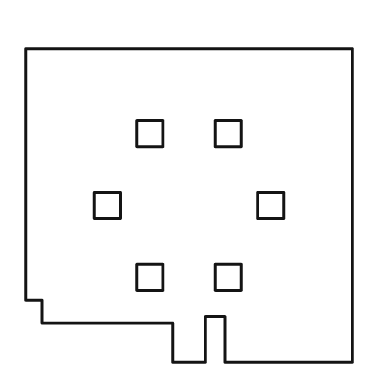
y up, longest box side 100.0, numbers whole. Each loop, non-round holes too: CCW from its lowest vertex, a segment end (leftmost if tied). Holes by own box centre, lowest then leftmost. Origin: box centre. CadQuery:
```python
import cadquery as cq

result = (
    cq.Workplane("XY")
    .moveTo(-5.0, -48.0)
    .lineTo(5.0, -48.0)
    .lineTo(5.0, -34.0)
    .lineTo(11.0, -34.0)
    .lineTo(11.0, -48.0)
    .lineTo(50.0, -48.0)
    .lineTo(50.0, 48.0)
    .lineTo(-50.0, 48.0)
    .lineTo(-50.0, -29.0)
    .lineTo(-45.0, -29.0)
    .lineTo(-45.0, -36.0)
    .lineTo(-5.0, -36.0)
    .close()
    .moveTo(-16.0, -26.0)
    .lineTo(-8.0, -26.0)
    .lineTo(-8.0, -18.0)
    .lineTo(-16.0, -18.0)
    .close()
    .moveTo(8.0, -26.0)
    .lineTo(16.0, -26.0)
    .lineTo(16.0, -18.0)
    .lineTo(8.0, -18.0)
    .close()
    .moveTo(-29.0, -4.0)
    .lineTo(-21.0, -4.0)
    .lineTo(-21.0, 4.0)
    .lineTo(-29.0, 4.0)
    .close()
    .moveTo(21.0, -4.0)
    .lineTo(29.0, -4.0)
    .lineTo(29.0, 4.0)
    .lineTo(21.0, 4.0)
    .close()
    .moveTo(-16.0, 18.0)
    .lineTo(-8.0, 18.0)
    .lineTo(-8.0, 26.0)
    .lineTo(-16.0, 26.0)
    .close()
    .moveTo(8.0, 18.0)
    .lineTo(16.0, 18.0)
    .lineTo(16.0, 26.0)
    .lineTo(8.0, 26.0)
    .close()
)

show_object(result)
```